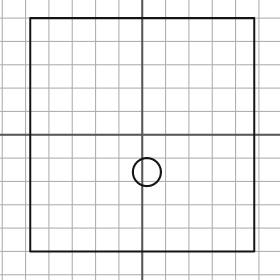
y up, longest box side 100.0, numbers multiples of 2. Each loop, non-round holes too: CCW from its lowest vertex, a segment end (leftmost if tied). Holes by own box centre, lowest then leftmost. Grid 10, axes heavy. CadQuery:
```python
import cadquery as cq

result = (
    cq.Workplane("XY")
    .moveTo(-48.0, -50.0)
    .lineTo(48.0, -50.0)
    .lineTo(48.0, 50.0)
    .lineTo(-48.0, 50.0)
    .close()
    .moveTo(2.0, -16.0)
    .circle(6.0)
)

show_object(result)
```